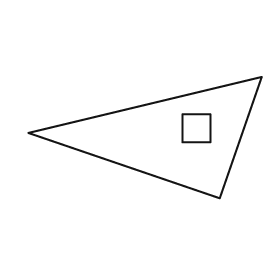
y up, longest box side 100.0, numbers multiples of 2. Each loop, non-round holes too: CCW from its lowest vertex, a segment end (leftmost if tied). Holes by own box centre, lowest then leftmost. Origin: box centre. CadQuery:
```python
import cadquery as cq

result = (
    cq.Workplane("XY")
    .moveTo(32.0, -26.0)
    .lineTo(50.0, 26.0)
    .lineTo(-50.0, 2.0)
    .close()
    .moveTo(16.0, -2.0)
    .lineTo(28.0, -2.0)
    .lineTo(28.0, 10.0)
    .lineTo(16.0, 10.0)
    .close()
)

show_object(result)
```